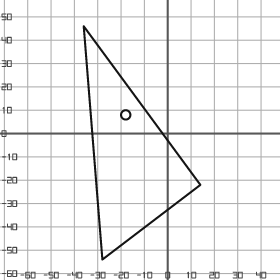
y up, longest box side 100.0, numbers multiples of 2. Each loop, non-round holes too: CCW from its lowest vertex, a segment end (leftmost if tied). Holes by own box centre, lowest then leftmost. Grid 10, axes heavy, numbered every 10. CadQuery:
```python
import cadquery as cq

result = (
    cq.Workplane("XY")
    .moveTo(-28.0, -54.0)
    .lineTo(14.0, -22.0)
    .lineTo(-36.0, 46.0)
    .close()
    .moveTo(-18.0, 8.0)
    .circle(2.0)
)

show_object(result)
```